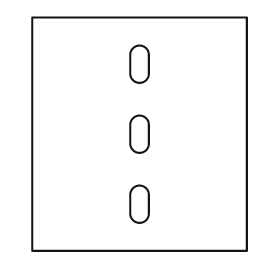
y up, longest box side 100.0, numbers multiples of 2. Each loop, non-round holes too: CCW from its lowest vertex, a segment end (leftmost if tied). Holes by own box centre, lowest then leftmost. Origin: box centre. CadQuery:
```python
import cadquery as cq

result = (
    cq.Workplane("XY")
    .moveTo(-46.0, -50.0)
    .lineTo(46.0, -50.0)
    .lineTo(46.0, 50.0)
    .lineTo(-46.0, 50.0)
    .close()
    .moveTo(-4.0, -34.0)
    .threePointArc((0.0, -38.0), (4.0, -34.0))
    .lineTo(4.0, -26.0)
    .threePointArc((0.0, -22.0), (-4.0, -26.0))
    .close()
    .moveTo(-4.0, -4.0)
    .threePointArc((0.0, -8.0), (4.0, -4.0))
    .lineTo(4.0, 4.0)
    .threePointArc((0.0, 8.0), (-4.0, 4.0))
    .close()
    .moveTo(-4.0, 26.0)
    .threePointArc((0.0, 22.0), (4.0, 26.0))
    .lineTo(4.0, 34.0)
    .threePointArc((0.0, 38.0), (-4.0, 34.0))
    .close()
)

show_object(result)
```